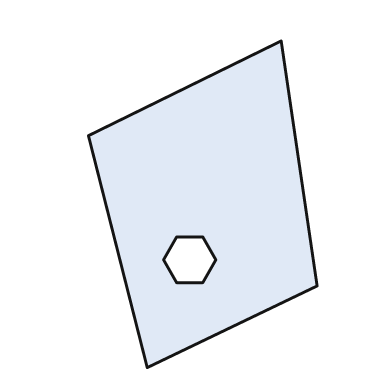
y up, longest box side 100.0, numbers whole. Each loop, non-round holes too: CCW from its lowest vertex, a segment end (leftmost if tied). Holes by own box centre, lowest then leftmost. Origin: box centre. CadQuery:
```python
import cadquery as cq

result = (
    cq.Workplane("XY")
    .moveTo(-17.0, -50.0)
    .lineTo(35.0, -25.0)
    .lineTo(24.0, 50.0)
    .lineTo(-35.0, 21.0)
    .close()
    .moveTo(-8.0, -24.0)
    .lineTo(0.0, -24.0)
    .lineTo(4.0, -17.0)
    .lineTo(0.0, -10.0)
    .lineTo(-8.0, -10.0)
    .lineTo(-12.0, -17.0)
    .close()
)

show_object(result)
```